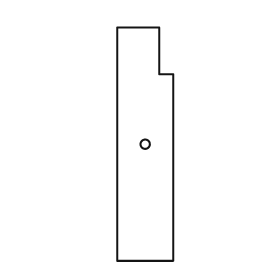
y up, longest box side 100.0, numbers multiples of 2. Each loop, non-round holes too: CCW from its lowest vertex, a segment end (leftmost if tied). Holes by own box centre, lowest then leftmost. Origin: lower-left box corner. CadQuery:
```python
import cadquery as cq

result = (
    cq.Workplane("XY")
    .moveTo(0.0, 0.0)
    .lineTo(24.0, 0.0)
    .lineTo(24.0, 80.0)
    .lineTo(18.0, 80.0)
    .lineTo(18.0, 100.0)
    .lineTo(0.0, 100.0)
    .close()
    .moveTo(12.0, 50.0)
    .circle(2.0)
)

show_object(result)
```